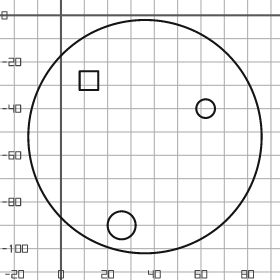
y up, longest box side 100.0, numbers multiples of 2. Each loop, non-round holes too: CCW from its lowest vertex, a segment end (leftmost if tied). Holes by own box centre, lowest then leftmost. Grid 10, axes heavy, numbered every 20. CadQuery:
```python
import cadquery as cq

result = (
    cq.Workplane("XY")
    .moveTo(36.0, -52.0)
    .circle(50.0)
    .moveTo(26.0, -90.0)
    .circle(6.0)
    .moveTo(62.0, -40.0)
    .circle(4.0)
    .moveTo(8.0, -32.0)
    .lineTo(16.0, -32.0)
    .lineTo(16.0, -24.0)
    .lineTo(8.0, -24.0)
    .close()
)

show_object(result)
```